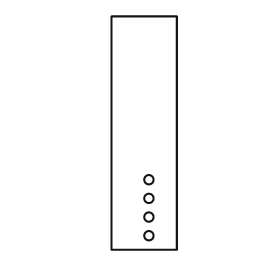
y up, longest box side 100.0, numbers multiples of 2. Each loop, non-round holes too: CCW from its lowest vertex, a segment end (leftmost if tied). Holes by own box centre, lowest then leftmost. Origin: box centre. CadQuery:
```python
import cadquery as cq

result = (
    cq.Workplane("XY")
    .moveTo(-14.0, -50.0)
    .lineTo(14.0, -50.0)
    .lineTo(14.0, 50.0)
    .lineTo(-14.0, 50.0)
    .close()
    .moveTo(2.0, -44.0)
    .circle(2.0)
    .moveTo(2.0, -36.0)
    .circle(2.0)
    .moveTo(2.0, -28.0)
    .circle(2.0)
    .moveTo(2.0, -20.0)
    .circle(2.0)
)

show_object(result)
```